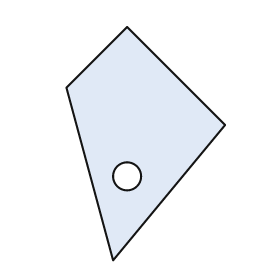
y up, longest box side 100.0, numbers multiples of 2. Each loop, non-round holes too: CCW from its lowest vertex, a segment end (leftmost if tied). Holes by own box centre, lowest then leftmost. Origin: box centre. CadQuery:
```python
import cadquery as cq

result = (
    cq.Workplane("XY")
    .moveTo(-14.0, -50.0)
    .lineTo(34.0, 8.0)
    .lineTo(-8.0, 50.0)
    .lineTo(-34.0, 24.0)
    .close()
    .moveTo(-8.0, -14.0)
    .circle(6.0)
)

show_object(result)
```